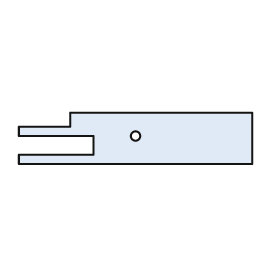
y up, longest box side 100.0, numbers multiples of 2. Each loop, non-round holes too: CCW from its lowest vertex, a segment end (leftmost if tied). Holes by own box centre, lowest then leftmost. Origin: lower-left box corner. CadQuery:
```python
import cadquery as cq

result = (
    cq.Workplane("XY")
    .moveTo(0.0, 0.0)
    .lineTo(100.0, 0.0)
    .lineTo(100.0, 22.0)
    .lineTo(22.0, 22.0)
    .lineTo(22.0, 16.0)
    .lineTo(0.0, 16.0)
    .lineTo(0.0, 12.0)
    .lineTo(32.0, 12.0)
    .lineTo(32.0, 4.0)
    .lineTo(0.0, 4.0)
    .close()
    .moveTo(50.0, 12.0)
    .circle(2.0)
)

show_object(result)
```